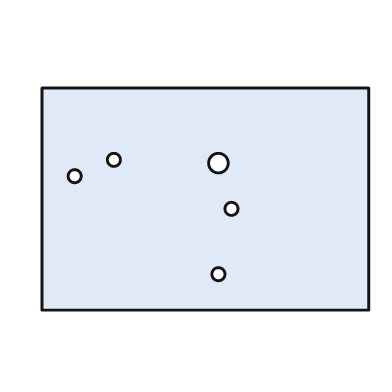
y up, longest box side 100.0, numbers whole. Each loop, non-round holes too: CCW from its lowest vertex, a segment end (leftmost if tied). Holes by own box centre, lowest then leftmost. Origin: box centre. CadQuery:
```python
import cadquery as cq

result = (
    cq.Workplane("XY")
    .moveTo(-50.0, -34.0)
    .lineTo(50.0, -34.0)
    .lineTo(50.0, 34.0)
    .lineTo(-50.0, 34.0)
    .close()
    .moveTo(4.0, -23.0)
    .circle(2.0)
    .moveTo(8.0, -3.0)
    .circle(2.0)
    .moveTo(-40.0, 7.0)
    .circle(2.0)
    .moveTo(4.0, 11.0)
    .circle(3.0)
    .moveTo(-28.0, 12.0)
    .circle(2.0)
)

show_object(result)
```